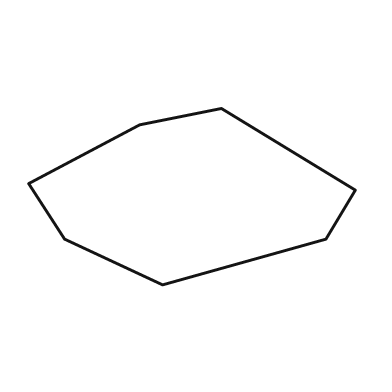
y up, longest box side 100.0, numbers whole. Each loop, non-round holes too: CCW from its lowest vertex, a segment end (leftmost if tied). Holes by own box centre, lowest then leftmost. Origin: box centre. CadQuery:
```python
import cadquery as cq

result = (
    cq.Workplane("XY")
    .moveTo(-9.0, -27.0)
    .lineTo(41.0, -13.0)
    .lineTo(50.0, 2.0)
    .lineTo(9.0, 27.0)
    .lineTo(-16.0, 22.0)
    .lineTo(-50.0, 4.0)
    .lineTo(-39.0, -13.0)
    .close()
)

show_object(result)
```